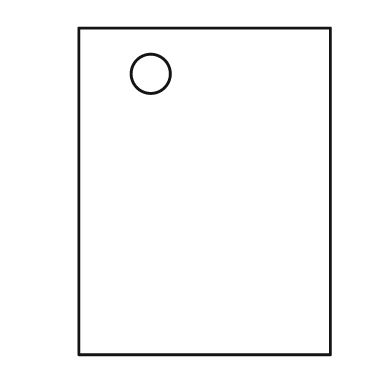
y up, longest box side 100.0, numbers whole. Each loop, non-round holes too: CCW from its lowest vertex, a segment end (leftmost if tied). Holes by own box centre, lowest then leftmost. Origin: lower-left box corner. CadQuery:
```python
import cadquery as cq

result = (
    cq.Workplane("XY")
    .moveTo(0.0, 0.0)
    .lineTo(77.0, 0.0)
    .lineTo(77.0, 100.0)
    .lineTo(0.0, 100.0)
    .close()
    .moveTo(22.0, 86.0)
    .circle(6.0)
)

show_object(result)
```